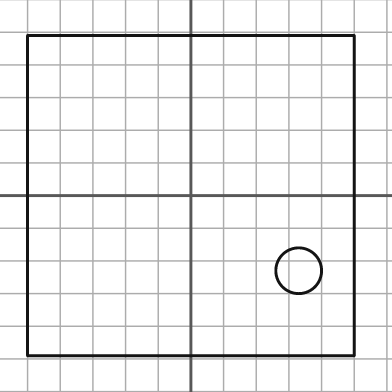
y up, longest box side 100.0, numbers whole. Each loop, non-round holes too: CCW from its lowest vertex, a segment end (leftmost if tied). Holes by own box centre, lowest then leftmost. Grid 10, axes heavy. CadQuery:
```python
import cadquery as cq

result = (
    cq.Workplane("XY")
    .moveTo(-50.0, -49.0)
    .lineTo(50.0, -49.0)
    .lineTo(50.0, 49.0)
    .lineTo(-50.0, 49.0)
    .close()
    .moveTo(33.0, -23.0)
    .circle(7.0)
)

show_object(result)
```